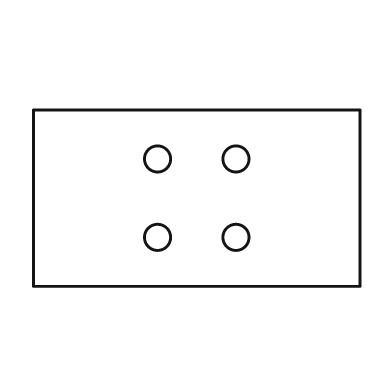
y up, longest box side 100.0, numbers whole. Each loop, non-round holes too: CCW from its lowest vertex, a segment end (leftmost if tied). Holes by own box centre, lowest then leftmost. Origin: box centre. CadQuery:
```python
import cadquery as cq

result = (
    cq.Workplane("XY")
    .moveTo(-50.0, -27.0)
    .lineTo(50.0, -27.0)
    .lineTo(50.0, 27.0)
    .lineTo(-50.0, 27.0)
    .close()
    .moveTo(-12.0, -12.0)
    .circle(4.0)
    .moveTo(12.0, -12.0)
    .circle(4.0)
    .moveTo(-12.0, 12.0)
    .circle(4.0)
    .moveTo(12.0, 12.0)
    .circle(4.0)
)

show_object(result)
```